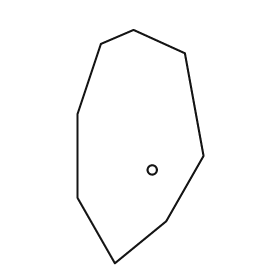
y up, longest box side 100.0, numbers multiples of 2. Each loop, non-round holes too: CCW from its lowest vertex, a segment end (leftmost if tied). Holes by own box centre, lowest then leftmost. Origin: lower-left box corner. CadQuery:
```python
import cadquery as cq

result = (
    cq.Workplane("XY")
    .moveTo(16.0, 0.0)
    .lineTo(38.0, 18.0)
    .lineTo(54.0, 46.0)
    .lineTo(46.0, 90.0)
    .lineTo(24.0, 100.0)
    .lineTo(10.0, 94.0)
    .lineTo(0.0, 64.0)
    .lineTo(0.0, 28.0)
    .close()
    .moveTo(32.0, 40.0)
    .circle(2.0)
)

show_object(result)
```